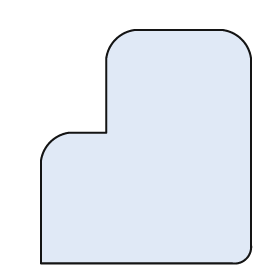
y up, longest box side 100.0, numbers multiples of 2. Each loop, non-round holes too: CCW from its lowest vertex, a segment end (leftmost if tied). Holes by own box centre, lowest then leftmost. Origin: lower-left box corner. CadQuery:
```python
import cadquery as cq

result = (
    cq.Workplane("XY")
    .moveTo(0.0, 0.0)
    .lineTo(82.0, 0.0)
    .threePointArc((88.0, 2.0), (90.0, 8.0))
    .lineTo(90.0, 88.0)
    .threePointArc((86.0, 96.0), (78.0, 100.0))
    .lineTo(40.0, 100.0)
    .threePointArc((32.0, 96.0), (28.0, 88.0))
    .lineTo(28.0, 56.0)
    .lineTo(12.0, 56.0)
    .threePointArc((4.0, 52.0), (0.0, 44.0))
    .close()
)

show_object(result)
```